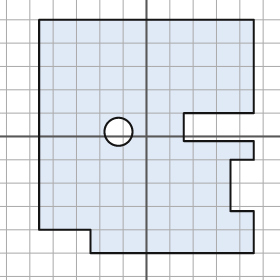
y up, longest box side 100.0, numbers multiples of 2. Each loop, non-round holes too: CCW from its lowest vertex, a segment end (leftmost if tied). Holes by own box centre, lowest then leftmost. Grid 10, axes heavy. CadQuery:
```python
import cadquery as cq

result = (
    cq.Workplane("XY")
    .moveTo(-24.0, -50.0)
    .lineTo(46.0, -50.0)
    .lineTo(46.0, -32.0)
    .lineTo(36.0, -32.0)
    .lineTo(36.0, -10.0)
    .lineTo(46.0, -10.0)
    .lineTo(46.0, -2.0)
    .lineTo(16.0, -2.0)
    .lineTo(16.0, 10.0)
    .lineTo(46.0, 10.0)
    .lineTo(46.0, 50.0)
    .lineTo(-46.0, 50.0)
    .lineTo(-46.0, -40.0)
    .lineTo(-24.0, -40.0)
    .close()
    .moveTo(-12.0, 2.0)
    .circle(6.0)
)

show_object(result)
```